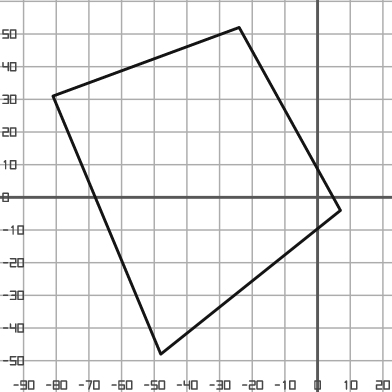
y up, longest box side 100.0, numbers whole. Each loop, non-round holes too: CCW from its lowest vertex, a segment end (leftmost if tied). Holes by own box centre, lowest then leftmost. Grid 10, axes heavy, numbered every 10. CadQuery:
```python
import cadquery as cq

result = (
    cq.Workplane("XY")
    .moveTo(-48.0, -48.0)
    .lineTo(7.0, -4.0)
    .lineTo(-24.0, 52.0)
    .lineTo(-81.0, 31.0)
    .close()
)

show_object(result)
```